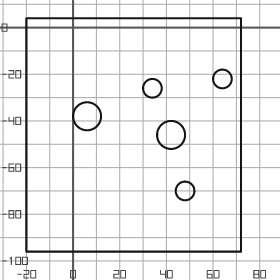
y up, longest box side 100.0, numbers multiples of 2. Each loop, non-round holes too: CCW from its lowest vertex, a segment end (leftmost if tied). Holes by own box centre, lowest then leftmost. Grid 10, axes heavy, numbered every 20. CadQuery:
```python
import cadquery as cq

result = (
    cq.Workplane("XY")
    .moveTo(-20.0, -96.0)
    .lineTo(72.0, -96.0)
    .lineTo(72.0, 4.0)
    .lineTo(-20.0, 4.0)
    .close()
    .moveTo(48.0, -70.0)
    .circle(4.0)
    .moveTo(42.0, -46.0)
    .circle(6.0)
    .moveTo(6.0, -38.0)
    .circle(6.0)
    .moveTo(34.0, -26.0)
    .circle(4.0)
    .moveTo(64.0, -22.0)
    .circle(4.0)
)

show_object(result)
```